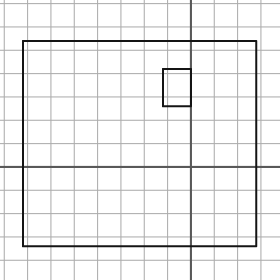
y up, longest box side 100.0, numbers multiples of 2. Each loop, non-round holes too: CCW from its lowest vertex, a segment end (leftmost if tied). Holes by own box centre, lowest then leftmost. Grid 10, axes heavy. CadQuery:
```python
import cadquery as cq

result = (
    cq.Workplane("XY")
    .moveTo(-72.0, -34.0)
    .lineTo(28.0, -34.0)
    .lineTo(28.0, 54.0)
    .lineTo(-72.0, 54.0)
    .close()
    .moveTo(-12.0, 26.0)
    .lineTo(0.0, 26.0)
    .lineTo(0.0, 42.0)
    .lineTo(-12.0, 42.0)
    .close()
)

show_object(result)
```